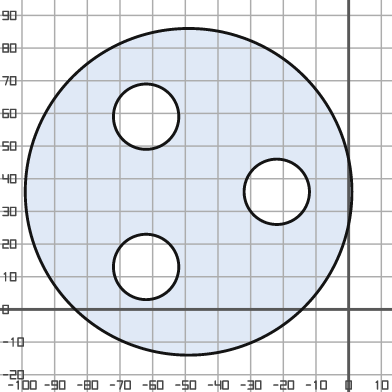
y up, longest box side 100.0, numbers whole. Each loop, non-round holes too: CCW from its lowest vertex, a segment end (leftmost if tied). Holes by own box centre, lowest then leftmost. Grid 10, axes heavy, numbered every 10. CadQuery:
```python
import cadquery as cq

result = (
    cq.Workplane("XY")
    .moveTo(-49.0, 36.0)
    .circle(50.0)
    .moveTo(-62.0, 13.0)
    .circle(10.0)
    .moveTo(-22.0, 36.0)
    .circle(10.0)
    .moveTo(-62.0, 59.0)
    .circle(10.0)
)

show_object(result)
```